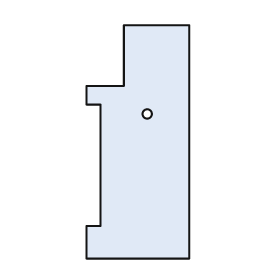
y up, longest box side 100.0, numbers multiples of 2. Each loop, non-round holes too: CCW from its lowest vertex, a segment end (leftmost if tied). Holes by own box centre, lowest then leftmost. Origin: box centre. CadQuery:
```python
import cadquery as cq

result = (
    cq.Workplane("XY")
    .moveTo(-22.0, -50.0)
    .lineTo(22.0, -50.0)
    .lineTo(22.0, 50.0)
    .lineTo(-6.0, 50.0)
    .lineTo(-6.0, 24.0)
    .lineTo(-22.0, 24.0)
    .lineTo(-22.0, 16.0)
    .lineTo(-16.0, 16.0)
    .lineTo(-16.0, -36.0)
    .lineTo(-22.0, -36.0)
    .close()
    .moveTo(4.0, 12.0)
    .circle(2.0)
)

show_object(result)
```